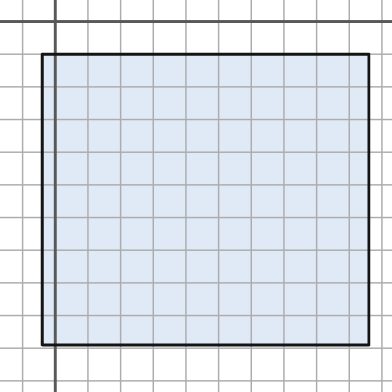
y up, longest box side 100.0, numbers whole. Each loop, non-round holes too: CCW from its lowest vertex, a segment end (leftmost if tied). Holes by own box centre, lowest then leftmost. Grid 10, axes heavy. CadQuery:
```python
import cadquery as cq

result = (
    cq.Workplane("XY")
    .moveTo(-4.0, -99.0)
    .lineTo(96.0, -99.0)
    .lineTo(96.0, -10.0)
    .lineTo(-4.0, -10.0)
    .close()
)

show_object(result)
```